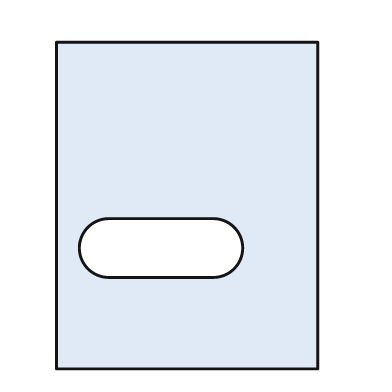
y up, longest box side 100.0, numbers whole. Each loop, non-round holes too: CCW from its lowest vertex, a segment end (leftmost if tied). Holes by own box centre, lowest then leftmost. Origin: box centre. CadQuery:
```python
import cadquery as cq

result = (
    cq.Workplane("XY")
    .moveTo(-40.0, -50.0)
    .lineTo(40.0, -50.0)
    .lineTo(40.0, 50.0)
    .lineTo(-40.0, 50.0)
    .close()
    .moveTo(-24.0, -22.0)
    .lineTo(8.0, -22.0)
    .threePointArc((17.0, -13.0), (8.0, -4.0))
    .lineTo(-24.0, -4.0)
    .threePointArc((-33.0, -13.0), (-24.0, -22.0))
    .close()
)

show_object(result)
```